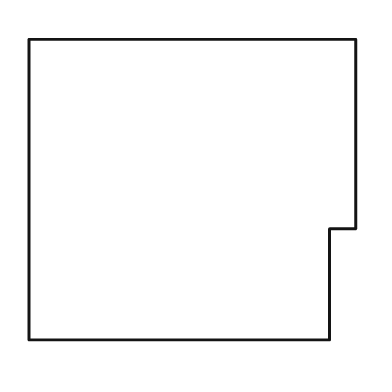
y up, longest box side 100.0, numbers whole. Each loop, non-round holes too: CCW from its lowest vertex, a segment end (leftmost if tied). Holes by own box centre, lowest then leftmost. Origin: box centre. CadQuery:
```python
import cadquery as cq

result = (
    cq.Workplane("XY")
    .moveTo(-50.0, -46.0)
    .lineTo(42.0, -46.0)
    .lineTo(42.0, -12.0)
    .lineTo(50.0, -12.0)
    .lineTo(50.0, 46.0)
    .lineTo(-50.0, 46.0)
    .close()
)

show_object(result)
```